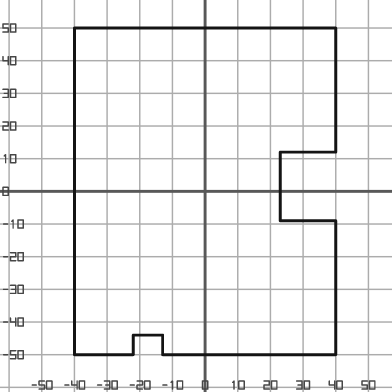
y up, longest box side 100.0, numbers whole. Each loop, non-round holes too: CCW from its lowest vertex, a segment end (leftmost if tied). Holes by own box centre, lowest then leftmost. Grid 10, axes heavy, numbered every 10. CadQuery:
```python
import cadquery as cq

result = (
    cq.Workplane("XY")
    .moveTo(-40.0, -50.0)
    .lineTo(-22.0, -50.0)
    .lineTo(-22.0, -44.0)
    .lineTo(-13.0, -44.0)
    .lineTo(-13.0, -50.0)
    .lineTo(40.0, -50.0)
    .lineTo(40.0, -9.0)
    .lineTo(23.0, -9.0)
    .lineTo(23.0, 12.0)
    .lineTo(40.0, 12.0)
    .lineTo(40.0, 50.0)
    .lineTo(-40.0, 50.0)
    .close()
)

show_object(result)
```